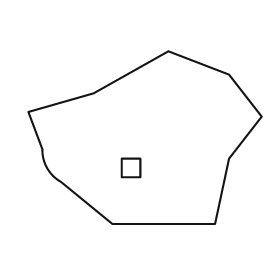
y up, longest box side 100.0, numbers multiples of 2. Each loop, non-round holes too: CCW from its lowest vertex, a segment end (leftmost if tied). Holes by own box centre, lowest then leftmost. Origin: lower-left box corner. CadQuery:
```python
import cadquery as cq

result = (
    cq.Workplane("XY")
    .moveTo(36.0, 0.0)
    .lineTo(80.0, 0.0)
    .lineTo(86.0, 28.0)
    .lineTo(100.0, 46.0)
    .lineTo(86.0, 64.0)
    .lineTo(60.0, 74.0)
    .lineTo(28.0, 56.0)
    .lineTo(0.0, 48.0)
    .lineTo(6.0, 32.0)
    .threePointArc((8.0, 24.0), (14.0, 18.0))
    .close()
    .moveTo(40.0, 20.0)
    .lineTo(48.0, 20.0)
    .lineTo(48.0, 28.0)
    .lineTo(40.0, 28.0)
    .close()
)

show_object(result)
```